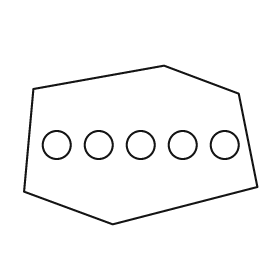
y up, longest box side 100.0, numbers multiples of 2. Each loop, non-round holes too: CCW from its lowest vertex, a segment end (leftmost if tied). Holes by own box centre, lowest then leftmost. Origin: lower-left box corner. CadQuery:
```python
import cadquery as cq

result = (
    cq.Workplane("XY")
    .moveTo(38.0, 0.0)
    .lineTo(100.0, 16.0)
    .lineTo(92.0, 56.0)
    .lineTo(60.0, 68.0)
    .lineTo(4.0, 58.0)
    .lineTo(0.0, 14.0)
    .close()
    .moveTo(14.0, 34.0)
    .circle(6.0)
    .moveTo(32.0, 34.0)
    .circle(6.0)
    .moveTo(50.0, 34.0)
    .circle(6.0)
    .moveTo(68.0, 34.0)
    .circle(6.0)
    .moveTo(86.0, 34.0)
    .circle(6.0)
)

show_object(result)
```